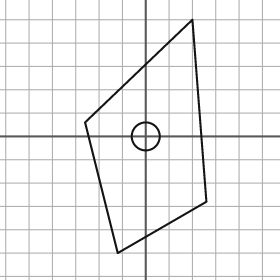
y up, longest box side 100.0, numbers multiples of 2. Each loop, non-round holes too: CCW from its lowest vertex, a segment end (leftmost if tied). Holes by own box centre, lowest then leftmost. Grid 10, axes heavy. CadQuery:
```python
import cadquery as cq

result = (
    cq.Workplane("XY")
    .moveTo(-12.0, -50.0)
    .lineTo(26.0, -28.0)
    .lineTo(20.0, 50.0)
    .lineTo(-26.0, 6.0)
    .close()
    .moveTo(0.0, 0.0)
    .circle(6.0)
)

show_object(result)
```